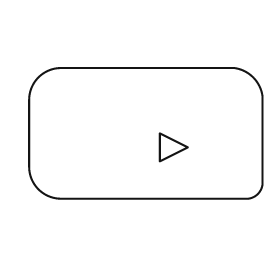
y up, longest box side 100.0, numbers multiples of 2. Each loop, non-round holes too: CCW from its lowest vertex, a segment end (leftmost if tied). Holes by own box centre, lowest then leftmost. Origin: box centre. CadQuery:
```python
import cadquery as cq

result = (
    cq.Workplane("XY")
    .moveTo(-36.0, -28.0)
    .lineTo(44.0, -28.0)
    .threePointArc((48.0, -26.0), (50.0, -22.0))
    .lineTo(50.0, 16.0)
    .threePointArc((46.0, 24.0), (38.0, 28.0))
    .lineTo(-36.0, 28.0)
    .threePointArc((-46.0, 24.0), (-50.0, 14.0))
    .lineTo(-50.0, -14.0)
    .threePointArc((-46.0, -24.0), (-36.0, -28.0))
    .close()
    .moveTo(6.0, -12.0)
    .lineTo(18.0, -6.0)
    .lineTo(6.0, 0.0)
    .close()
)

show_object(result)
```